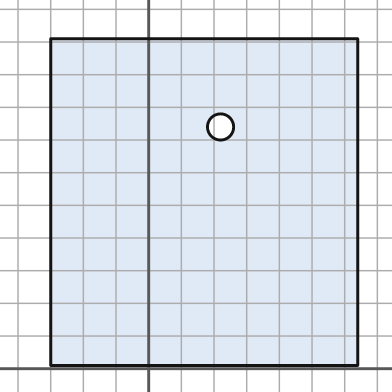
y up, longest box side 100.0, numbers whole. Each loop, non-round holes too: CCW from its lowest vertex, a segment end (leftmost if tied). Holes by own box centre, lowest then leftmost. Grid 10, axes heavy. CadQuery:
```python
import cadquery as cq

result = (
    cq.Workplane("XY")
    .moveTo(-30.0, 1.0)
    .lineTo(64.0, 1.0)
    .lineTo(64.0, 101.0)
    .lineTo(-30.0, 101.0)
    .close()
    .moveTo(22.0, 74.0)
    .circle(4.0)
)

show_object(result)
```